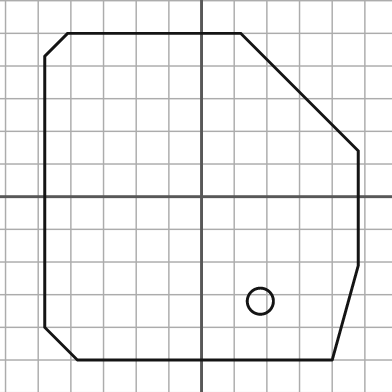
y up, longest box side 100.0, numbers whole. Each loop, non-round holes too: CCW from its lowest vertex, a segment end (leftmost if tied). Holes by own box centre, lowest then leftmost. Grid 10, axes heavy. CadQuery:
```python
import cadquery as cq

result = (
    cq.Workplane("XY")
    .moveTo(-38.0, -50.0)
    .lineTo(40.0, -50.0)
    .lineTo(48.0, -21.0)
    .lineTo(48.0, 14.0)
    .lineTo(12.0, 50.0)
    .lineTo(-41.0, 50.0)
    .lineTo(-48.0, 43.0)
    .lineTo(-48.0, -40.0)
    .close()
    .moveTo(18.0, -32.0)
    .circle(4.0)
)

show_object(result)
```